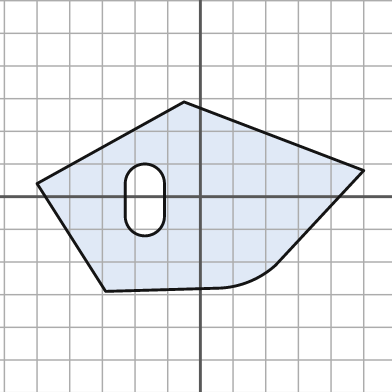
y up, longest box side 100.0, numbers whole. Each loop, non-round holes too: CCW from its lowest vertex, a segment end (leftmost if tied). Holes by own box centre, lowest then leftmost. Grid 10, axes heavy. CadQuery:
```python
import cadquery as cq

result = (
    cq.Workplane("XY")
    .moveTo(-29.0, -29.0)
    .lineTo(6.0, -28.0)
    .threePointArc((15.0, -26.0), (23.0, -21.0))
    .lineTo(50.0, 8.0)
    .lineTo(-5.0, 29.0)
    .lineTo(-50.0, 4.0)
    .close()
    .moveTo(-23.0, -6.0)
    .threePointArc((-17.0, -12.0), (-11.0, -6.0))
    .lineTo(-11.0, 4.0)
    .threePointArc((-17.0, 10.0), (-23.0, 4.0))
    .close()
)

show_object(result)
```